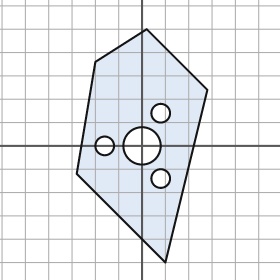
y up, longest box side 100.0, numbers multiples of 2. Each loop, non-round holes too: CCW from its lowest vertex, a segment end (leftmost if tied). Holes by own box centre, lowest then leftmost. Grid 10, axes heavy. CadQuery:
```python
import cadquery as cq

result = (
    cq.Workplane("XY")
    .moveTo(10.0, -50.0)
    .lineTo(28.0, 24.0)
    .lineTo(2.0, 50.0)
    .lineTo(-20.0, 36.0)
    .lineTo(-28.0, -12.0)
    .close()
    .moveTo(8.0, -14.0)
    .circle(4.0)
    .moveTo(-16.0, 0.0)
    .circle(4.0)
    .moveTo(0.0, 0.0)
    .circle(8.0)
    .moveTo(8.0, 14.0)
    .circle(4.0)
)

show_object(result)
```